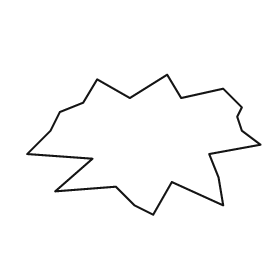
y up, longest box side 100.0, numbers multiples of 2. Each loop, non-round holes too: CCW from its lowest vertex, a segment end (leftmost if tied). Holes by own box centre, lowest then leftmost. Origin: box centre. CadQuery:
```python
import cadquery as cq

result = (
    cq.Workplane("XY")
    .moveTo(4.0, -30.0)
    .lineTo(12.0, -16.0)
    .lineTo(34.0, -26.0)
    .lineTo(32.0, -14.0)
    .lineTo(28.0, -4.0)
    .lineTo(50.0, 0.0)
    .lineTo(42.0, 6.0)
    .lineTo(40.0, 12.0)
    .lineTo(42.0, 16.0)
    .lineTo(34.0, 24.0)
    .lineTo(16.0, 20.0)
    .lineTo(10.0, 30.0)
    .lineTo(-6.0, 20.0)
    .lineTo(-20.0, 28.0)
    .lineTo(-26.0, 18.0)
    .lineTo(-36.0, 14.0)
    .lineTo(-40.0, 6.0)
    .lineTo(-50.0, -4.0)
    .lineTo(-22.0, -6.0)
    .lineTo(-38.0, -20.0)
    .lineTo(-12.0, -18.0)
    .lineTo(-4.0, -26.0)
    .close()
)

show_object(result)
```